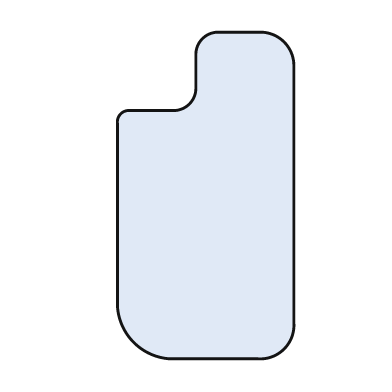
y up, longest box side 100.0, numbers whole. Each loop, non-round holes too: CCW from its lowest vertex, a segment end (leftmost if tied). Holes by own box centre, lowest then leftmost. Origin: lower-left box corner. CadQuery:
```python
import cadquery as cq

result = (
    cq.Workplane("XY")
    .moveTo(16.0, 0.0)
    .lineTo(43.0, 0.0)
    .threePointArc((51.0, 3.0), (54.0, 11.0))
    .lineTo(54.0, 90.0)
    .threePointArc((51.0, 97.0), (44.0, 100.0))
    .lineTo(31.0, 100.0)
    .threePointArc((26.0, 98.0), (24.0, 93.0))
    .lineTo(24.0, 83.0)
    .threePointArc((22.0, 78.0), (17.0, 76.0))
    .lineTo(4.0, 76.0)
    .threePointArc((1.0, 75.0), (0.0, 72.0))
    .lineTo(0.0, 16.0)
    .threePointArc((5.0, 5.0), (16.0, 0.0))
    .close()
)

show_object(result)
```